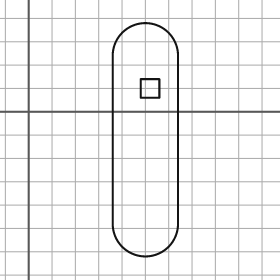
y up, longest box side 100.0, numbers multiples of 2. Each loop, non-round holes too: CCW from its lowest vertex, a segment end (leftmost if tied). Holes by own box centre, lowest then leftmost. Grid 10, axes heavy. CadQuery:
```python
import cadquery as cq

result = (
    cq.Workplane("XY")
    .moveTo(36.0, -48.0)
    .threePointArc((50.0, -62.0), (64.0, -48.0))
    .lineTo(64.0, 24.0)
    .threePointArc((50.0, 38.0), (36.0, 24.0))
    .close()
    .moveTo(48.0, 6.0)
    .lineTo(56.0, 6.0)
    .lineTo(56.0, 14.0)
    .lineTo(48.0, 14.0)
    .close()
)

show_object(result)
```